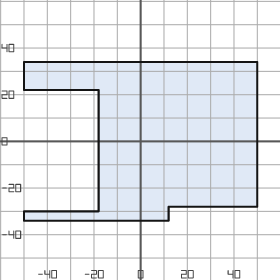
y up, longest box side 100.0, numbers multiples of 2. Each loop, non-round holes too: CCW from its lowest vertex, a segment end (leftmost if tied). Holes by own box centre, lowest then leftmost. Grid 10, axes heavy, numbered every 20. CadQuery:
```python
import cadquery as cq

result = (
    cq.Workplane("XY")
    .moveTo(-50.0, -34.0)
    .lineTo(12.0, -34.0)
    .lineTo(12.0, -28.0)
    .lineTo(50.0, -28.0)
    .lineTo(50.0, 34.0)
    .lineTo(-50.0, 34.0)
    .lineTo(-50.0, 22.0)
    .lineTo(-18.0, 22.0)
    .lineTo(-18.0, -30.0)
    .lineTo(-50.0, -30.0)
    .close()
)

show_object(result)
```